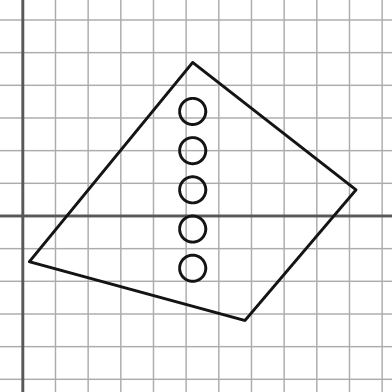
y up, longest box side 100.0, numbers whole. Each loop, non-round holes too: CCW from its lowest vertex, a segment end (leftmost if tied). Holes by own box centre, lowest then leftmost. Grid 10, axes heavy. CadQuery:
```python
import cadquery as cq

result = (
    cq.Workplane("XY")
    .moveTo(68.0, -32.0)
    .lineTo(102.0, 8.0)
    .lineTo(52.0, 47.0)
    .lineTo(2.0, -14.0)
    .close()
    .moveTo(52.0, -16.0)
    .circle(4.0)
    .moveTo(52.0, -4.0)
    .circle(4.0)
    .moveTo(52.0, 8.0)
    .circle(4.0)
    .moveTo(52.0, 20.0)
    .circle(4.0)
    .moveTo(52.0, 32.0)
    .circle(4.0)
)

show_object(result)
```